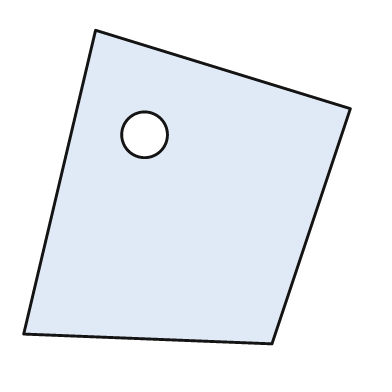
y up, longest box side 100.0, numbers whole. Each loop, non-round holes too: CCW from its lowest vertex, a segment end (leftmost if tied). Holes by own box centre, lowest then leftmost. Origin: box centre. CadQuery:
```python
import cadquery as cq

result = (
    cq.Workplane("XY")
    .moveTo(26.0, -48.0)
    .lineTo(50.0, 24.0)
    .lineTo(-28.0, 48.0)
    .lineTo(-50.0, -45.0)
    .close()
    .moveTo(-13.0, 16.0)
    .circle(7.0)
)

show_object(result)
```